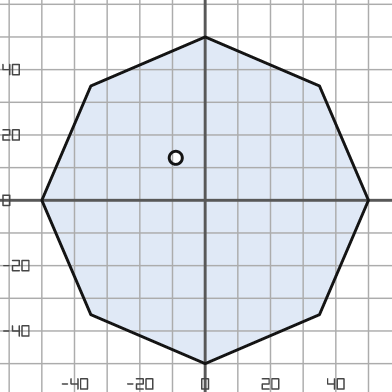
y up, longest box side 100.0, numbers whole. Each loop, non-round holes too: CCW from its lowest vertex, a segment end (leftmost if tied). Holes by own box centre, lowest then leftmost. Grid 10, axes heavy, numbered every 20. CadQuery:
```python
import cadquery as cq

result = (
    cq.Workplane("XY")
    .moveTo(0.0, -50.0)
    .lineTo(35.0, -35.0)
    .lineTo(50.0, 0.0)
    .lineTo(35.0, 35.0)
    .lineTo(0.0, 50.0)
    .lineTo(-35.0, 35.0)
    .lineTo(-50.0, 0.0)
    .lineTo(-35.0, -35.0)
    .close()
    .moveTo(-9.0, 13.0)
    .circle(2.0)
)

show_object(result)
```